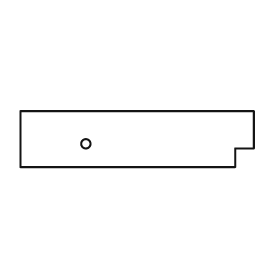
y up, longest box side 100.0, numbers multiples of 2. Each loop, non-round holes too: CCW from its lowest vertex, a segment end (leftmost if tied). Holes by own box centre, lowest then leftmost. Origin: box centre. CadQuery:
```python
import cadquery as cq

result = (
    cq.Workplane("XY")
    .moveTo(-50.0, -12.0)
    .lineTo(42.0, -12.0)
    .lineTo(42.0, -4.0)
    .lineTo(50.0, -4.0)
    .lineTo(50.0, 12.0)
    .lineTo(-50.0, 12.0)
    .close()
    .moveTo(-22.0, -2.0)
    .circle(2.0)
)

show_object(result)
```